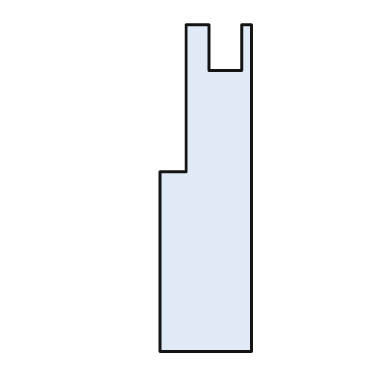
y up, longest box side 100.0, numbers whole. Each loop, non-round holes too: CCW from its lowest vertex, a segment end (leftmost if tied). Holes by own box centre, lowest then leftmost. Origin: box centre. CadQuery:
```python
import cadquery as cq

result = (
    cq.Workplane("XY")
    .moveTo(-14.0, -50.0)
    .lineTo(14.0, -50.0)
    .lineTo(14.0, 50.0)
    .lineTo(11.0, 50.0)
    .lineTo(11.0, 36.0)
    .lineTo(1.0, 36.0)
    .lineTo(1.0, 50.0)
    .lineTo(-6.0, 50.0)
    .lineTo(-6.0, 5.0)
    .lineTo(-14.0, 5.0)
    .close()
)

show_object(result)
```